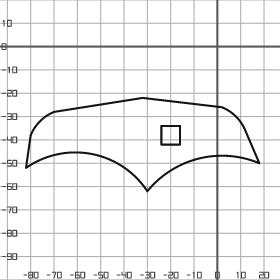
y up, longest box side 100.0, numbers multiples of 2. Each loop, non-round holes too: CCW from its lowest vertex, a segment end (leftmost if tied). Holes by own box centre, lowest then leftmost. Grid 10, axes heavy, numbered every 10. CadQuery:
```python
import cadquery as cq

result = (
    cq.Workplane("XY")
    .moveTo(-30.0, -62.0)
    .threePointArc((-8.0, -48.0), (18.0, -50.0))
    .lineTo(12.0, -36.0)
    .threePointArc((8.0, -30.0), (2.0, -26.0))
    .lineTo(-32.0, -22.0)
    .lineTo(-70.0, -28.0)
    .threePointArc((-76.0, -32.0), (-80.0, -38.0))
    .lineTo(-82.0, -52.0)
    .threePointArc((-54.0, -46.0), (-30.0, -62.0))
    .close()
    .moveTo(-24.0, -42.0)
    .lineTo(-16.0, -42.0)
    .lineTo(-16.0, -34.0)
    .lineTo(-24.0, -34.0)
    .close()
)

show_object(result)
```